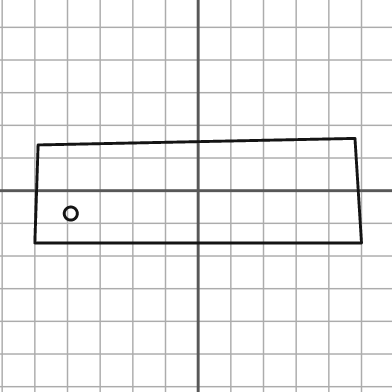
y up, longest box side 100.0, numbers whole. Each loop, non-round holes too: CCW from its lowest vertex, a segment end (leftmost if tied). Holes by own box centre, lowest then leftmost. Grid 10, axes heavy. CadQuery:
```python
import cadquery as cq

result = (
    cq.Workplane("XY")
    .moveTo(-50.0, -16.0)
    .lineTo(50.0, -16.0)
    .lineTo(48.0, 16.0)
    .lineTo(-49.0, 14.0)
    .close()
    .moveTo(-39.0, -7.0)
    .circle(2.0)
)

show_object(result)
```